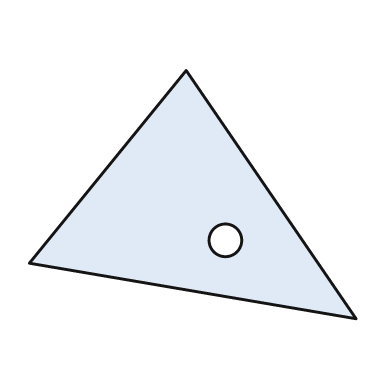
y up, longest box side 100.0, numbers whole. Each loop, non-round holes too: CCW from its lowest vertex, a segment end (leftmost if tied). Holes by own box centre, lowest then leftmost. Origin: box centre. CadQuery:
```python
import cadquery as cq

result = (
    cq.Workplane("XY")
    .moveTo(50.0, -38.0)
    .lineTo(-2.0, 38.0)
    .lineTo(-50.0, -21.0)
    .close()
    .moveTo(10.0, -14.0)
    .circle(5.0)
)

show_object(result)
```